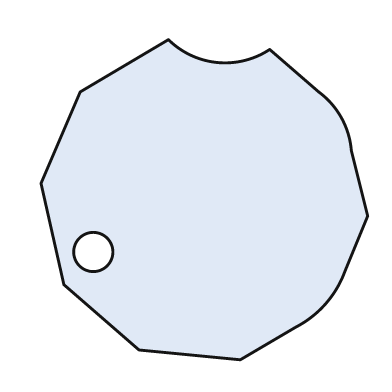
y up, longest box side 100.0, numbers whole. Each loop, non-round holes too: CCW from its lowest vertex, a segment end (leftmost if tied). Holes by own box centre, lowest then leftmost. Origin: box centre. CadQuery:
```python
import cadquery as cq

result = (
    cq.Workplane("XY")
    .moveTo(11.0, -49.0)
    .lineTo(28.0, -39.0)
    .threePointArc((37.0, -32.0), (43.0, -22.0))
    .lineTo(50.0, -5.0)
    .lineTo(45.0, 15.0)
    .threePointArc((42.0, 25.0), (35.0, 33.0))
    .lineTo(20.0, 46.0)
    .threePointArc((4.0, 42.0), (-11.0, 49.0))
    .lineTo(-38.0, 33.0)
    .lineTo(-50.0, 5.0)
    .lineTo(-43.0, -26.0)
    .lineTo(-20.0, -46.0)
    .close()
    .moveTo(-34.0, -16.0)
    .circle(6.0)
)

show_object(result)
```